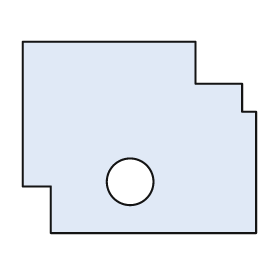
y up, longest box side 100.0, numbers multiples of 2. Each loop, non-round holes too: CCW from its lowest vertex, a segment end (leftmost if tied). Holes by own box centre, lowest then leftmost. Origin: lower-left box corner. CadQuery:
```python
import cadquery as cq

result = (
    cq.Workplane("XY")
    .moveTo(12.0, 0.0)
    .lineTo(100.0, 0.0)
    .lineTo(100.0, 52.0)
    .lineTo(94.0, 52.0)
    .lineTo(94.0, 64.0)
    .lineTo(74.0, 64.0)
    .lineTo(74.0, 82.0)
    .lineTo(0.0, 82.0)
    .lineTo(0.0, 20.0)
    .lineTo(12.0, 20.0)
    .close()
    .moveTo(46.0, 22.0)
    .circle(10.0)
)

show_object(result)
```